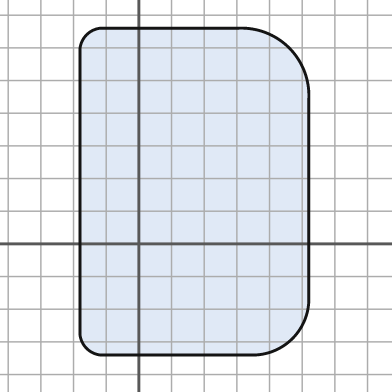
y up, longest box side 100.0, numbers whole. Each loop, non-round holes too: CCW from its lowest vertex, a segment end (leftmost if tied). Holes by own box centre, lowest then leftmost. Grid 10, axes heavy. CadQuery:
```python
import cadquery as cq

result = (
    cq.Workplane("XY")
    .moveTo(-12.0, -34.0)
    .lineTo(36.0, -34.0)
    .threePointArc((47.0, -29.0), (52.0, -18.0))
    .lineTo(52.0, 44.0)
    .threePointArc((46.0, 60.0), (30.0, 66.0))
    .lineTo(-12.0, 66.0)
    .threePointArc((-16.0, 64.0), (-18.0, 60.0))
    .lineTo(-18.0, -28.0)
    .threePointArc((-16.0, -32.0), (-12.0, -34.0))
    .close()
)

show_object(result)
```